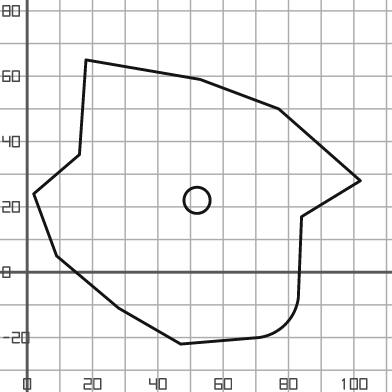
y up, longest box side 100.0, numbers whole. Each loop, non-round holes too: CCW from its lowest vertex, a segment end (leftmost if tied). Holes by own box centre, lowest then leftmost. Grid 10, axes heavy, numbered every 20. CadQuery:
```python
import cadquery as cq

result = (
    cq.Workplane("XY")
    .moveTo(47.0, -22.0)
    .lineTo(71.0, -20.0)
    .threePointArc((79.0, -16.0), (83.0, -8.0))
    .lineTo(84.0, 17.0)
    .lineTo(102.0, 28.0)
    .lineTo(77.0, 50.0)
    .lineTo(53.0, 59.0)
    .lineTo(18.0, 65.0)
    .lineTo(16.0, 36.0)
    .lineTo(2.0, 24.0)
    .lineTo(9.0, 5.0)
    .lineTo(28.0, -11.0)
    .close()
    .moveTo(52.0, 22.0)
    .circle(4.0)
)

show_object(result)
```